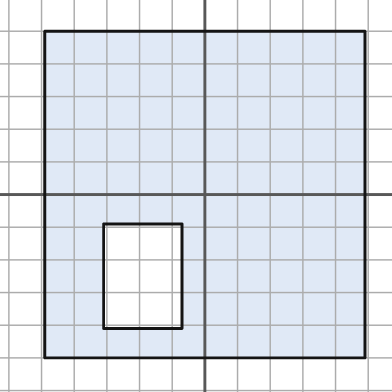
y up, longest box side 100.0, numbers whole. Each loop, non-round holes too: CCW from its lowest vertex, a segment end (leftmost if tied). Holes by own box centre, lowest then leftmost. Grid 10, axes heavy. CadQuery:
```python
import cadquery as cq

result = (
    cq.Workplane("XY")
    .moveTo(-49.0, -50.0)
    .lineTo(49.0, -50.0)
    .lineTo(49.0, 50.0)
    .lineTo(-49.0, 50.0)
    .close()
    .moveTo(-31.0, -41.0)
    .lineTo(-7.0, -41.0)
    .lineTo(-7.0, -9.0)
    .lineTo(-31.0, -9.0)
    .close()
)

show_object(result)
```